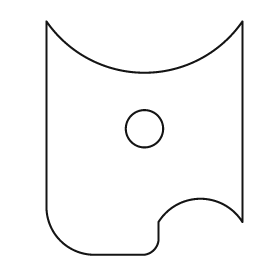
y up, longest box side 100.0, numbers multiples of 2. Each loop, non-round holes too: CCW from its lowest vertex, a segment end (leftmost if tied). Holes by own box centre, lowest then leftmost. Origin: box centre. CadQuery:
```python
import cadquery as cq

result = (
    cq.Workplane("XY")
    .moveTo(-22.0, -50.0)
    .lineTo(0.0, -50.0)
    .threePointArc((4.0, -48.0), (6.0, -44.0))
    .lineTo(6.0, -36.0)
    .threePointArc((24.0, -26.0), (42.0, -36.0))
    .lineTo(42.0, 50.0)
    .threePointArc((0.0, 28.0), (-42.0, 50.0))
    .lineTo(-42.0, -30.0)
    .threePointArc((-36.0, -44.0), (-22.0, -50.0))
    .close()
    .moveTo(0.0, 4.0)
    .circle(8.0)
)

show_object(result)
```